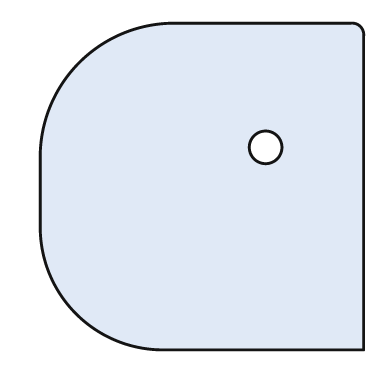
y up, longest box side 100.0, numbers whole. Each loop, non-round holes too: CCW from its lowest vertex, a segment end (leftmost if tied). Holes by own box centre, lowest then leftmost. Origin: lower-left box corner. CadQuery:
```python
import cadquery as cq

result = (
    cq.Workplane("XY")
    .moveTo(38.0, 0.0)
    .lineTo(99.0, 0.0)
    .lineTo(99.0, 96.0)
    .threePointArc((98.0, 99.0), (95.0, 100.0))
    .lineTo(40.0, 100.0)
    .threePointArc((12.0, 88.0), (0.0, 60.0))
    .lineTo(0.0, 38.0)
    .threePointArc((11.0, 11.0), (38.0, 0.0))
    .close()
    .moveTo(69.0, 62.0)
    .circle(5.0)
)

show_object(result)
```